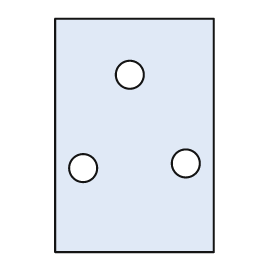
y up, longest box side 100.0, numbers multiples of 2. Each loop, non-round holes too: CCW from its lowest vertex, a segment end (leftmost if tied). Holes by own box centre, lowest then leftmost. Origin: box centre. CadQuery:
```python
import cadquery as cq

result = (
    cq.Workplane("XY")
    .moveTo(-34.0, -50.0)
    .lineTo(34.0, -50.0)
    .lineTo(34.0, 50.0)
    .lineTo(-34.0, 50.0)
    .close()
    .moveTo(-22.0, -14.0)
    .circle(6.0)
    .moveTo(22.0, -12.0)
    .circle(6.0)
    .moveTo(-2.0, 26.0)
    .circle(6.0)
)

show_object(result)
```